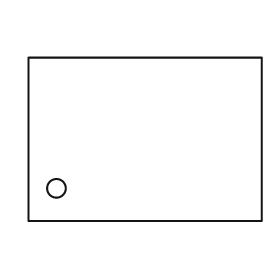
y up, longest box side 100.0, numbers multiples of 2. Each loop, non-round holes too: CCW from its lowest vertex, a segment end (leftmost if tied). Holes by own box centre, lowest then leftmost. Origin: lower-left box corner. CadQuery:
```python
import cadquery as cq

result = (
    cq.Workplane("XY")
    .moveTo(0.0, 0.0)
    .lineTo(100.0, 0.0)
    .lineTo(100.0, 70.0)
    .lineTo(0.0, 70.0)
    .close()
    .moveTo(12.0, 14.0)
    .circle(4.0)
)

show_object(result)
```